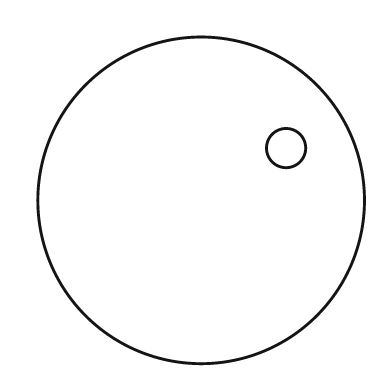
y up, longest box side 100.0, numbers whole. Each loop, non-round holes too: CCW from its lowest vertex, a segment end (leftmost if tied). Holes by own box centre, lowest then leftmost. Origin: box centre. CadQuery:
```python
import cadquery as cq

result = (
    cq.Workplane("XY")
    .moveTo(0.0, 0.0)
    .circle(50.0)
    .moveTo(26.0, 16.0)
    .circle(6.0)
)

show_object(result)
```